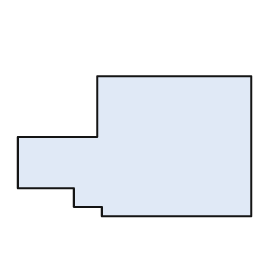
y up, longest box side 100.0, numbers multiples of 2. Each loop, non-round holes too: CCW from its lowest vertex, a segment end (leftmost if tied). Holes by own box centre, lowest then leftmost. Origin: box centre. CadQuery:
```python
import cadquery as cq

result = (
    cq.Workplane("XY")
    .moveTo(-14.0, -30.0)
    .lineTo(50.0, -30.0)
    .lineTo(50.0, 30.0)
    .lineTo(-16.0, 30.0)
    .lineTo(-16.0, 4.0)
    .lineTo(-50.0, 4.0)
    .lineTo(-50.0, -18.0)
    .lineTo(-26.0, -18.0)
    .lineTo(-26.0, -26.0)
    .lineTo(-14.0, -26.0)
    .close()
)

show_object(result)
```